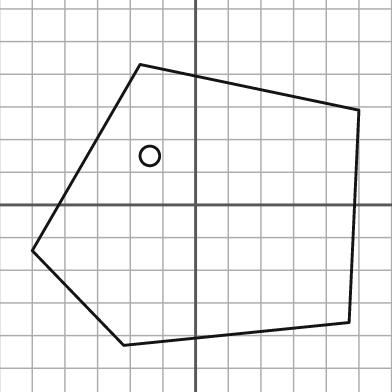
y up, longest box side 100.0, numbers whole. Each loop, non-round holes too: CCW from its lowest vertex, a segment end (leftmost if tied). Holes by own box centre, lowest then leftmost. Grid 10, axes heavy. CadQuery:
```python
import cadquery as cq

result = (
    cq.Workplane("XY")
    .moveTo(-22.0, -43.0)
    .lineTo(47.0, -36.0)
    .lineTo(50.0, 29.0)
    .lineTo(-17.0, 43.0)
    .lineTo(-50.0, -14.0)
    .close()
    .moveTo(-14.0, 15.0)
    .circle(3.0)
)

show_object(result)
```